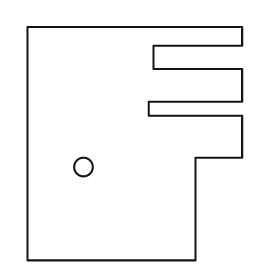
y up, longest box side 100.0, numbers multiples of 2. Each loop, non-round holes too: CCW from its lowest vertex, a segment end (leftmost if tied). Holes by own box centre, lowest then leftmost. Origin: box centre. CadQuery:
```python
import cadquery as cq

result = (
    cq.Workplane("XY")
    .moveTo(-46.0, -50.0)
    .lineTo(26.0, -50.0)
    .lineTo(26.0, -6.0)
    .lineTo(46.0, -6.0)
    .lineTo(46.0, 12.0)
    .lineTo(6.0, 12.0)
    .lineTo(6.0, 18.0)
    .lineTo(46.0, 18.0)
    .lineTo(46.0, 32.0)
    .lineTo(8.0, 32.0)
    .lineTo(8.0, 42.0)
    .lineTo(46.0, 42.0)
    .lineTo(46.0, 50.0)
    .lineTo(-46.0, 50.0)
    .close()
    .moveTo(-22.0, -10.0)
    .circle(4.0)
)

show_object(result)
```